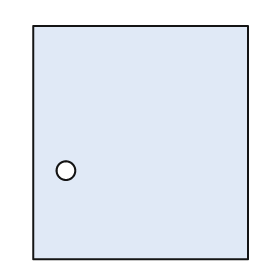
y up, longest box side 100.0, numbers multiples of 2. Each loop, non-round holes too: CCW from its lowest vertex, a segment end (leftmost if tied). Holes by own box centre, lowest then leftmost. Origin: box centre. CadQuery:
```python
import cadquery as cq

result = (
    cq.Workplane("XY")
    .moveTo(-46.0, -50.0)
    .lineTo(46.0, -50.0)
    .lineTo(46.0, 50.0)
    .lineTo(-46.0, 50.0)
    .close()
    .moveTo(-32.0, -12.0)
    .circle(4.0)
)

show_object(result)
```